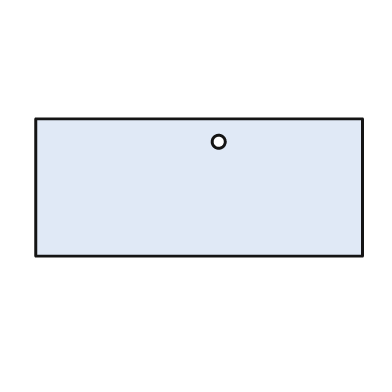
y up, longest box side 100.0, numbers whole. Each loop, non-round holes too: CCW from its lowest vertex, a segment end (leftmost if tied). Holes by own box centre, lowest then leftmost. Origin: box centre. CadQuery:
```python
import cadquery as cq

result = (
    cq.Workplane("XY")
    .moveTo(-50.0, -21.0)
    .lineTo(50.0, -21.0)
    .lineTo(50.0, 21.0)
    .lineTo(-50.0, 21.0)
    .close()
    .moveTo(6.0, 14.0)
    .circle(2.0)
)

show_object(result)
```